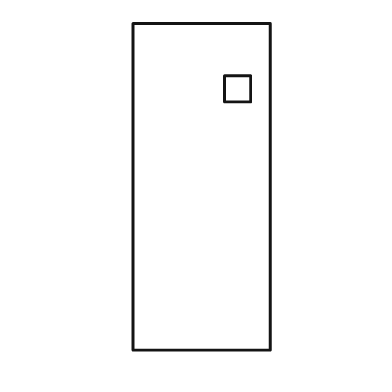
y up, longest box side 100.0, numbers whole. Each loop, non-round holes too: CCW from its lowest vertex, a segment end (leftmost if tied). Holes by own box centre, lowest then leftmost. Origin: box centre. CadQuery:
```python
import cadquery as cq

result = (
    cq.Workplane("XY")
    .moveTo(-21.0, -50.0)
    .lineTo(21.0, -50.0)
    .lineTo(21.0, 50.0)
    .lineTo(-21.0, 50.0)
    .close()
    .moveTo(7.0, 26.0)
    .lineTo(15.0, 26.0)
    .lineTo(15.0, 34.0)
    .lineTo(7.0, 34.0)
    .close()
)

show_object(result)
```